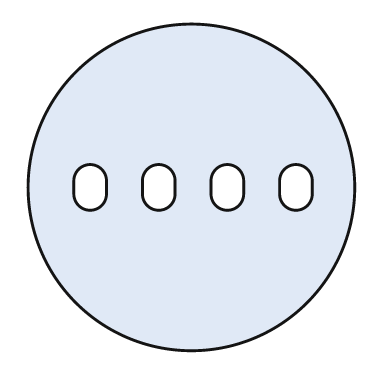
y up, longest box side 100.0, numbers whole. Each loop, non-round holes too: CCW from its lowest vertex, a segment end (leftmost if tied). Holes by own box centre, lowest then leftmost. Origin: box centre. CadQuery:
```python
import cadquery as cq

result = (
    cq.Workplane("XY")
    .moveTo(0.0, 0.0)
    .circle(50.0)
    .moveTo(-36.0, -2.0)
    .threePointArc((-31.0, -7.0), (-26.0, -2.0))
    .lineTo(-26.0, 2.0)
    .threePointArc((-31.0, 7.0), (-36.0, 2.0))
    .close()
    .moveTo(-15.0, -2.0)
    .threePointArc((-10.0, -7.0), (-5.0, -2.0))
    .lineTo(-5.0, 2.0)
    .threePointArc((-10.0, 7.0), (-15.0, 2.0))
    .close()
    .moveTo(6.0, -2.0)
    .threePointArc((11.0, -7.0), (16.0, -2.0))
    .lineTo(16.0, 2.0)
    .threePointArc((11.0, 7.0), (6.0, 2.0))
    .close()
    .moveTo(27.0, -2.0)
    .threePointArc((32.0, -7.0), (37.0, -2.0))
    .lineTo(37.0, 2.0)
    .threePointArc((32.0, 7.0), (27.0, 2.0))
    .close()
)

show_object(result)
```